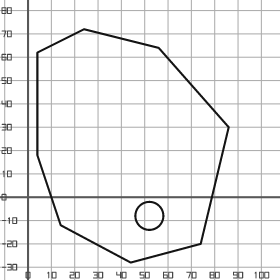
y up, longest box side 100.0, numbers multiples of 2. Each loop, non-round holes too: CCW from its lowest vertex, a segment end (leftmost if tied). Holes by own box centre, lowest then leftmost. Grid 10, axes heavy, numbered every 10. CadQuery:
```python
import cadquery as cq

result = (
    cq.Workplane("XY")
    .moveTo(44.0, -28.0)
    .lineTo(74.0, -20.0)
    .lineTo(86.0, 30.0)
    .lineTo(56.0, 64.0)
    .lineTo(24.0, 72.0)
    .lineTo(4.0, 62.0)
    .lineTo(4.0, 18.0)
    .lineTo(14.0, -12.0)
    .close()
    .moveTo(52.0, -8.0)
    .circle(6.0)
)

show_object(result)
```